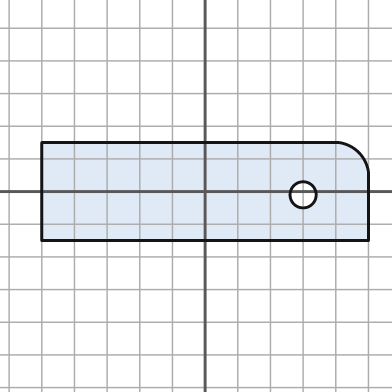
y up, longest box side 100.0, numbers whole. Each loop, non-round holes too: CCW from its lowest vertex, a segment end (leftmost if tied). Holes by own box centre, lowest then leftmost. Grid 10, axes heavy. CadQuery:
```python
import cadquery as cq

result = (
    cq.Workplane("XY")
    .moveTo(-50.0, -15.0)
    .lineTo(50.0, -15.0)
    .lineTo(50.0, 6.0)
    .threePointArc((47.0, 12.0), (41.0, 15.0))
    .lineTo(-50.0, 15.0)
    .close()
    .moveTo(30.0, -1.0)
    .circle(4.0)
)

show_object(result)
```